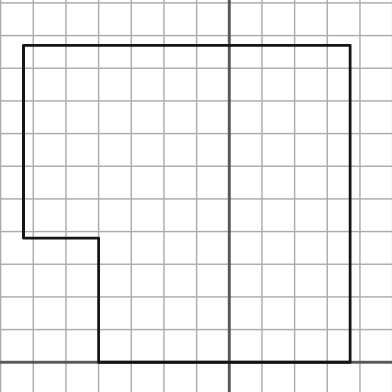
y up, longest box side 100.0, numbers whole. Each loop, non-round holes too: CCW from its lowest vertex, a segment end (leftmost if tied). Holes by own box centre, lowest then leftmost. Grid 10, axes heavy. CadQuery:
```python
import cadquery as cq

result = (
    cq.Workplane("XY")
    .moveTo(-40.0, 0.0)
    .lineTo(37.0, 0.0)
    .lineTo(37.0, 97.0)
    .lineTo(-63.0, 97.0)
    .lineTo(-63.0, 38.0)
    .lineTo(-40.0, 38.0)
    .close()
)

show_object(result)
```